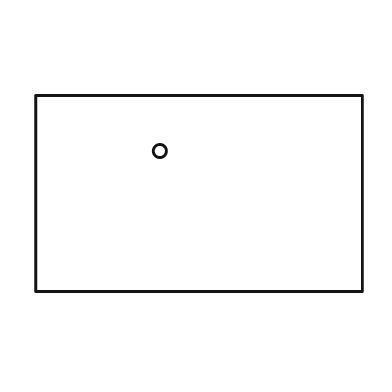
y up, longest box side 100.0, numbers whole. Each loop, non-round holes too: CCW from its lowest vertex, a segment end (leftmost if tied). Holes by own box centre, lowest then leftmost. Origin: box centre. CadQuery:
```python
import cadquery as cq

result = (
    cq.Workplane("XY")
    .moveTo(-50.0, -30.0)
    .lineTo(50.0, -30.0)
    .lineTo(50.0, 30.0)
    .lineTo(-50.0, 30.0)
    .close()
    .moveTo(-12.0, 13.0)
    .circle(2.0)
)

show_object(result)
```